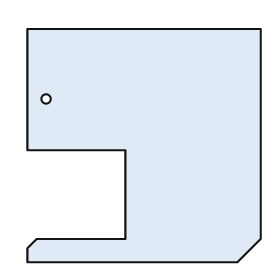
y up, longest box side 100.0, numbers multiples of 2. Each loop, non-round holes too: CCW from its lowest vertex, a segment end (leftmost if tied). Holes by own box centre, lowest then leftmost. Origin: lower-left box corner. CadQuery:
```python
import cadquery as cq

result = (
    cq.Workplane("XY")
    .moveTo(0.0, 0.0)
    .lineTo(90.0, 0.0)
    .lineTo(100.0, 10.0)
    .lineTo(100.0, 100.0)
    .lineTo(0.0, 100.0)
    .lineTo(0.0, 48.0)
    .lineTo(42.0, 48.0)
    .lineTo(42.0, 10.0)
    .lineTo(4.0, 10.0)
    .lineTo(0.0, 6.0)
    .close()
    .moveTo(8.0, 70.0)
    .circle(2.0)
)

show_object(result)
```